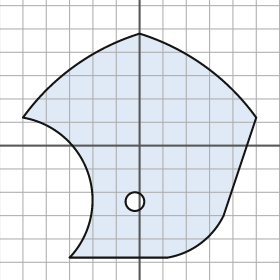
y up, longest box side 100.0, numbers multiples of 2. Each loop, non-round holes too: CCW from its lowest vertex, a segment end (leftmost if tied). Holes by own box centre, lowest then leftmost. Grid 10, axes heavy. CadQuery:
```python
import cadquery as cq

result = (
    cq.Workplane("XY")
    .moveTo(-30.0, -48.0)
    .lineTo(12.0, -48.0)
    .threePointArc((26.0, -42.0), (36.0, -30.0))
    .lineTo(50.0, 12.0)
    .threePointArc((28.0, 34.0), (0.0, 48.0))
    .threePointArc((-28.0, 34.0), (-50.0, 12.0))
    .threePointArc((-22.0, -12.0), (-30.0, -48.0))
    .close()
    .moveTo(-2.0, -24.0)
    .circle(4.0)
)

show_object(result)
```